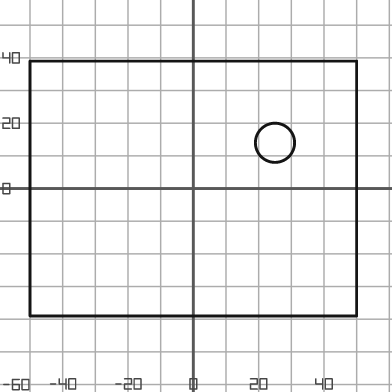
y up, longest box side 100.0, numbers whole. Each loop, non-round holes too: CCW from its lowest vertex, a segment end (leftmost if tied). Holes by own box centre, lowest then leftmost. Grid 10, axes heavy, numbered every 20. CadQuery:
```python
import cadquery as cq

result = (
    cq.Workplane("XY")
    .moveTo(-50.0, -39.0)
    .lineTo(50.0, -39.0)
    .lineTo(50.0, 39.0)
    .lineTo(-50.0, 39.0)
    .close()
    .moveTo(25.0, 14.0)
    .circle(6.0)
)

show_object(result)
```